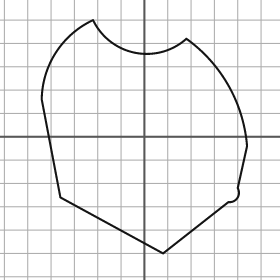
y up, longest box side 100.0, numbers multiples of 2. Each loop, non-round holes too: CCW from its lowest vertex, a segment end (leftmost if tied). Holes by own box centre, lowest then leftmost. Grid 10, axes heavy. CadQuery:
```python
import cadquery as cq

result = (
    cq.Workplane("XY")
    .moveTo(8.0, -50.0)
    .lineTo(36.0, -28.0)
    .threePointArc((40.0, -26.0), (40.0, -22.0))
    .lineTo(44.0, -4.0)
    .threePointArc((36.0, 22.0), (18.0, 42.0))
    .threePointArc((-4.0, 36.0), (-22.0, 50.0))
    .threePointArc((-38.0, 36.0), (-44.0, 16.0))
    .lineTo(-36.0, -26.0)
    .close()
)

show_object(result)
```